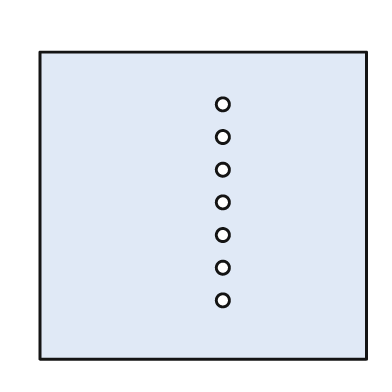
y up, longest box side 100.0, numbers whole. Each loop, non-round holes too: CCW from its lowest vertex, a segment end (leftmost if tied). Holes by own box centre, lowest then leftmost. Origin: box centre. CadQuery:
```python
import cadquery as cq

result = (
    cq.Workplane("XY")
    .moveTo(-50.0, -47.0)
    .lineTo(50.0, -47.0)
    .lineTo(50.0, 47.0)
    .lineTo(-50.0, 47.0)
    .close()
    .moveTo(6.0, -29.0)
    .circle(2.0)
    .moveTo(6.0, -19.0)
    .circle(2.0)
    .moveTo(6.0, -9.0)
    .circle(2.0)
    .moveTo(6.0, 1.0)
    .circle(2.0)
    .moveTo(6.0, 11.0)
    .circle(2.0)
    .moveTo(6.0, 21.0)
    .circle(2.0)
    .moveTo(6.0, 31.0)
    .circle(2.0)
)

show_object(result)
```